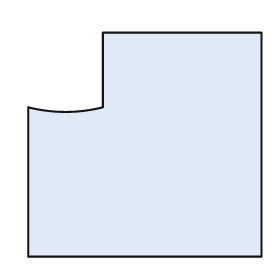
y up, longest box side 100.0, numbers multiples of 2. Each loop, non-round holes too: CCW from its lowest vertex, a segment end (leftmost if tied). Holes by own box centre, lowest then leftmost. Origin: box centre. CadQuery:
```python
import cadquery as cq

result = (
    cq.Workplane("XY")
    .moveTo(-50.0, -48.0)
    .lineTo(50.0, -48.0)
    .lineTo(50.0, 48.0)
    .lineTo(-18.0, 48.0)
    .lineTo(-18.0, 16.0)
    .threePointArc((-34.0, 14.0), (-50.0, 16.0))
    .close()
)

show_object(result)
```